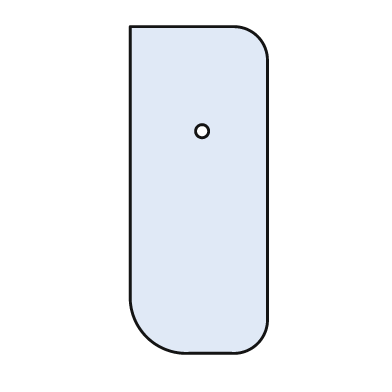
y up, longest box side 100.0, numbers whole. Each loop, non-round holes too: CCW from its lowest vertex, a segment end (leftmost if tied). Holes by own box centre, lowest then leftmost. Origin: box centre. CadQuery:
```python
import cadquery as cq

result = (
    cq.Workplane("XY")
    .moveTo(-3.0, -50.0)
    .lineTo(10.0, -50.0)
    .threePointArc((18.0, -47.0), (21.0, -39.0))
    .lineTo(21.0, 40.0)
    .threePointArc((18.0, 47.0), (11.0, 50.0))
    .lineTo(-21.0, 50.0)
    .lineTo(-21.0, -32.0)
    .threePointArc((-16.0, -45.0), (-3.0, -50.0))
    .close()
    .moveTo(1.0, 18.0)
    .circle(2.0)
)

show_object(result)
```